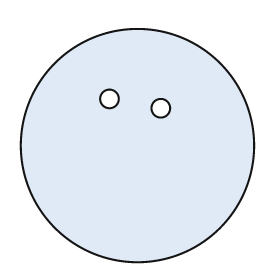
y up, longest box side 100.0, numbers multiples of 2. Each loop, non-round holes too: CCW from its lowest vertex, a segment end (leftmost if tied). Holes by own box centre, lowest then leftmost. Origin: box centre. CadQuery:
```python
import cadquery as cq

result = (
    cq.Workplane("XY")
    .moveTo(0.0, 0.0)
    .circle(50.0)
    .moveTo(10.0, 16.0)
    .circle(4.0)
    .moveTo(-12.0, 20.0)
    .circle(4.0)
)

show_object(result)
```